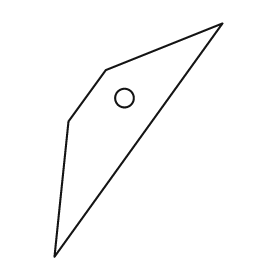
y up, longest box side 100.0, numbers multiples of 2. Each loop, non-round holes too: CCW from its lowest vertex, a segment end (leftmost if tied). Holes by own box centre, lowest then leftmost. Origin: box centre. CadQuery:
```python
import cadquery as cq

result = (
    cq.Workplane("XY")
    .moveTo(-36.0, -50.0)
    .lineTo(36.0, 50.0)
    .lineTo(-14.0, 30.0)
    .lineTo(-30.0, 8.0)
    .close()
    .moveTo(-6.0, 18.0)
    .circle(4.0)
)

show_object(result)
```